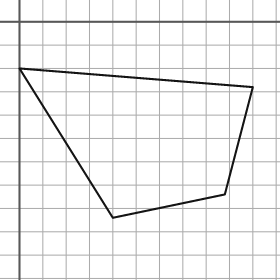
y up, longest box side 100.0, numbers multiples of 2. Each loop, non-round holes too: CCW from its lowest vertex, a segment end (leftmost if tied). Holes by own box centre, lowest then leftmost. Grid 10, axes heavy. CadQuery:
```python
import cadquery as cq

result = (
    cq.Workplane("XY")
    .moveTo(40.0, -84.0)
    .lineTo(88.0, -74.0)
    .lineTo(100.0, -28.0)
    .lineTo(0.0, -20.0)
    .close()
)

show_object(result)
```